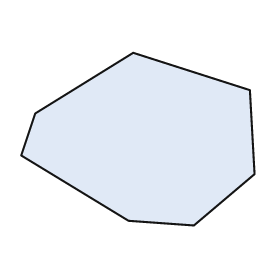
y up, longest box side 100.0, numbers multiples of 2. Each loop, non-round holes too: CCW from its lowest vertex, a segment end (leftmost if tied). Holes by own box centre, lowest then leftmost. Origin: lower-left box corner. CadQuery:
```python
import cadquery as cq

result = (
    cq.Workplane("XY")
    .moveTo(74.0, 0.0)
    .lineTo(100.0, 22.0)
    .lineTo(98.0, 58.0)
    .lineTo(48.0, 74.0)
    .lineTo(6.0, 48.0)
    .lineTo(0.0, 30.0)
    .lineTo(46.0, 2.0)
    .close()
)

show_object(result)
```